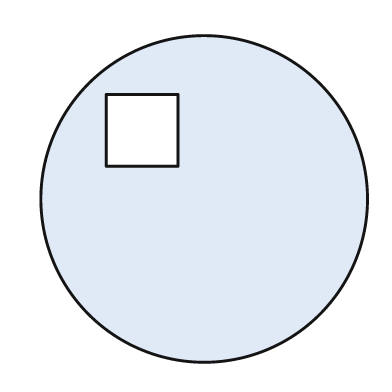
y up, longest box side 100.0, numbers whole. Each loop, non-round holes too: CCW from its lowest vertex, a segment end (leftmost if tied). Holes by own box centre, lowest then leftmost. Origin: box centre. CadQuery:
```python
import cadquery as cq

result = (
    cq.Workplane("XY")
    .moveTo(0.0, 0.0)
    .circle(50.0)
    .moveTo(-30.0, 10.0)
    .lineTo(-8.0, 10.0)
    .lineTo(-8.0, 32.0)
    .lineTo(-30.0, 32.0)
    .close()
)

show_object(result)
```